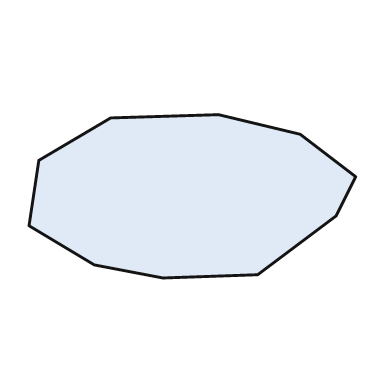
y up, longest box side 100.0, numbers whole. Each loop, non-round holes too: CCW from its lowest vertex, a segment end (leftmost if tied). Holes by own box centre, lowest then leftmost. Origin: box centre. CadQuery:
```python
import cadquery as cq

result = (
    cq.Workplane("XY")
    .moveTo(-9.0, -25.0)
    .lineTo(20.0, -24.0)
    .lineTo(44.0, -6.0)
    .lineTo(50.0, 6.0)
    .lineTo(33.0, 19.0)
    .lineTo(8.0, 25.0)
    .lineTo(-25.0, 24.0)
    .lineTo(-47.0, 11.0)
    .lineTo(-50.0, -9.0)
    .lineTo(-30.0, -21.0)
    .close()
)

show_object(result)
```